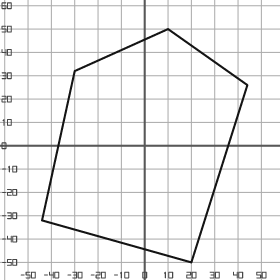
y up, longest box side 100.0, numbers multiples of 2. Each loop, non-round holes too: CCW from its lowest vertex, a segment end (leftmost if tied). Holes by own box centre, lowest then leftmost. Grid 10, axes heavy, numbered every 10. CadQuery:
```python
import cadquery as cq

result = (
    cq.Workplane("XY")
    .moveTo(20.0, -50.0)
    .lineTo(44.0, 26.0)
    .lineTo(10.0, 50.0)
    .lineTo(-30.0, 32.0)
    .lineTo(-44.0, -32.0)
    .close()
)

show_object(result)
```